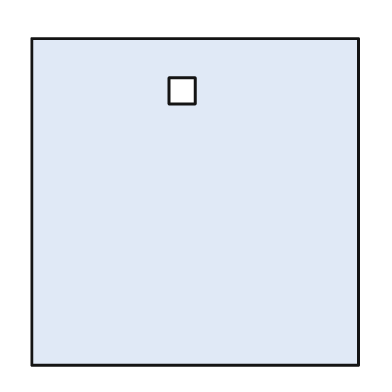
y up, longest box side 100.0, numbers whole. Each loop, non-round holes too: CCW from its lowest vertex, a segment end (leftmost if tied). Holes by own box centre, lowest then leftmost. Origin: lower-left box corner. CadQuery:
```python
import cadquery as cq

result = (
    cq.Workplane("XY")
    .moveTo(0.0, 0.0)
    .lineTo(100.0, 0.0)
    .lineTo(100.0, 100.0)
    .lineTo(0.0, 100.0)
    .close()
    .moveTo(42.0, 80.0)
    .lineTo(50.0, 80.0)
    .lineTo(50.0, 88.0)
    .lineTo(42.0, 88.0)
    .close()
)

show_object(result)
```